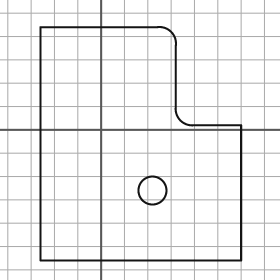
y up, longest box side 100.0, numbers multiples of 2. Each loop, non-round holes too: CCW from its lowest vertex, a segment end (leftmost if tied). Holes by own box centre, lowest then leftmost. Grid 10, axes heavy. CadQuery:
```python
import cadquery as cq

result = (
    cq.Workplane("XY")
    .moveTo(-26.0, -56.0)
    .lineTo(60.0, -56.0)
    .lineTo(60.0, 2.0)
    .lineTo(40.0, 2.0)
    .threePointArc((34.0, 4.0), (32.0, 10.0))
    .lineTo(32.0, 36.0)
    .threePointArc((30.0, 42.0), (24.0, 44.0))
    .lineTo(-26.0, 44.0)
    .close()
    .moveTo(22.0, -26.0)
    .circle(6.0)
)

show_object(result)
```